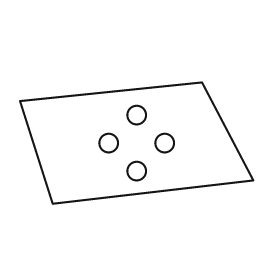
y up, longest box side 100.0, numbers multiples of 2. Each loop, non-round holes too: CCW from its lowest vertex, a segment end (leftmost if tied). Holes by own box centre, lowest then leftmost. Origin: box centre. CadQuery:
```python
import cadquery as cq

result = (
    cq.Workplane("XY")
    .moveTo(-36.0, -26.0)
    .lineTo(50.0, -16.0)
    .lineTo(28.0, 26.0)
    .lineTo(-50.0, 18.0)
    .close()
    .moveTo(0.0, -12.0)
    .circle(4.0)
    .moveTo(-12.0, 0.0)
    .circle(4.0)
    .moveTo(12.0, 0.0)
    .circle(4.0)
    .moveTo(0.0, 12.0)
    .circle(4.0)
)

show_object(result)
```